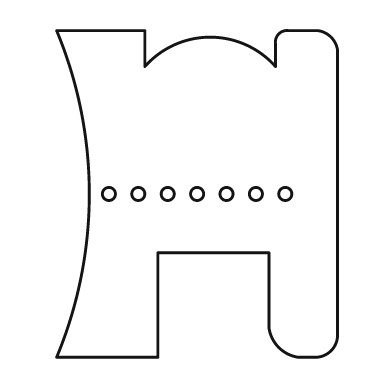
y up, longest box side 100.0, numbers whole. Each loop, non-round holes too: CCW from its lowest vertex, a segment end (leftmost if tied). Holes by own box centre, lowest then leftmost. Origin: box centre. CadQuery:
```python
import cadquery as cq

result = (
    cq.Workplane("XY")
    .moveTo(-43.0, -50.0)
    .lineTo(-12.0, -50.0)
    .lineTo(-12.0, -18.0)
    .lineTo(22.0, -18.0)
    .lineTo(22.0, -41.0)
    .threePointArc((25.0, -47.0), (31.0, -50.0))
    .lineTo(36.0, -50.0)
    .threePointArc((41.0, -48.0), (43.0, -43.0))
    .lineTo(43.0, 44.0)
    .threePointArc((41.0, 48.0), (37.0, 50.0))
    .lineTo(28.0, 50.0)
    .threePointArc((25.0, 49.0), (24.0, 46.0))
    .lineTo(24.0, 39.0)
    .threePointArc((4.0, 48.0), (-16.0, 39.0))
    .lineTo(-16.0, 50.0)
    .lineTo(-43.0, 50.0)
    .threePointArc((-33.0, 0.0), (-43.0, -50.0))
    .close()
    .moveTo(-27.0, 0.0)
    .circle(2.0)
    .moveTo(-18.0, 0.0)
    .circle(2.0)
    .moveTo(-9.0, 0.0)
    .circle(2.0)
    .moveTo(0.0, 0.0)
    .circle(2.0)
    .moveTo(9.0, 0.0)
    .circle(2.0)
    .moveTo(18.0, 0.0)
    .circle(2.0)
    .moveTo(27.0, 0.0)
    .circle(2.0)
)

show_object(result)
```